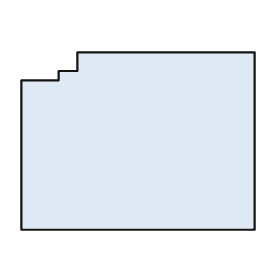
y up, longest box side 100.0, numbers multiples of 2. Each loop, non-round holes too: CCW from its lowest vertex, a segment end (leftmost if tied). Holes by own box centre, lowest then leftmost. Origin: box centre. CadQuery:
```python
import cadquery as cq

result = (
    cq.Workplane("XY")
    .moveTo(-50.0, -38.0)
    .lineTo(50.0, -38.0)
    .lineTo(50.0, 38.0)
    .lineTo(-26.0, 38.0)
    .lineTo(-26.0, 30.0)
    .lineTo(-34.0, 30.0)
    .lineTo(-34.0, 26.0)
    .lineTo(-50.0, 26.0)
    .close()
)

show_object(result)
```